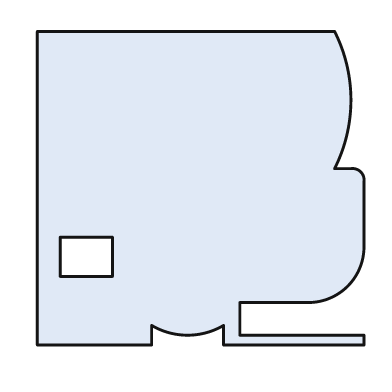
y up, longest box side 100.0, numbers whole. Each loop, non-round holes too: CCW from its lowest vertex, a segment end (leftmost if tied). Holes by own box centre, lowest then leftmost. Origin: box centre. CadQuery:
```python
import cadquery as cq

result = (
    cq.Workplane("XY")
    .moveTo(-50.0, -48.0)
    .lineTo(-15.0, -48.0)
    .lineTo(-15.0, -42.0)
    .threePointArc((-4.0, -45.0), (7.0, -42.0))
    .lineTo(7.0, -48.0)
    .lineTo(50.0, -48.0)
    .lineTo(50.0, -45.0)
    .lineTo(12.0, -45.0)
    .lineTo(12.0, -35.0)
    .lineTo(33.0, -35.0)
    .threePointArc((45.0, -30.0), (50.0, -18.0))
    .lineTo(50.0, 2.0)
    .threePointArc((49.0, 5.0), (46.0, 6.0))
    .lineTo(41.0, 6.0)
    .threePointArc((46.0, 27.0), (41.0, 48.0))
    .lineTo(-50.0, 48.0)
    .close()
    .moveTo(-43.0, -27.0)
    .lineTo(-27.0, -27.0)
    .lineTo(-27.0, -15.0)
    .lineTo(-43.0, -15.0)
    .close()
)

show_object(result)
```